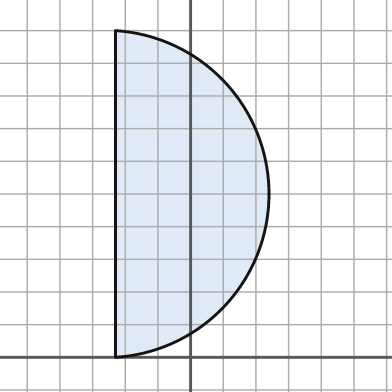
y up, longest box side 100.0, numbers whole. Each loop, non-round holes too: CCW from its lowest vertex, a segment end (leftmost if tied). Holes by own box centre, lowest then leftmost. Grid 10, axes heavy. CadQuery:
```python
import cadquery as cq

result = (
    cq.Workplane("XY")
    .moveTo(-23.0, 0.0)
    .threePointArc((24.0, 50.0), (-23.0, 100.0))
    .close()
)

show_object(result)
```